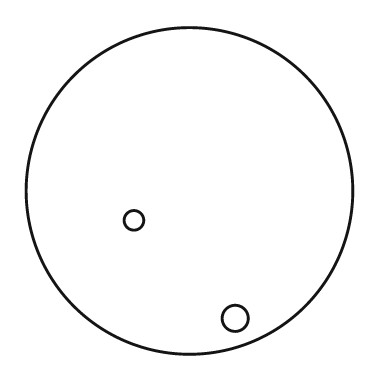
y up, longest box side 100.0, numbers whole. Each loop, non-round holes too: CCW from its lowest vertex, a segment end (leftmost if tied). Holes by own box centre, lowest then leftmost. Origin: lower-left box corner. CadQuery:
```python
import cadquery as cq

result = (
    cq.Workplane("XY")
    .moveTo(50.0, 50.0)
    .circle(50.0)
    .moveTo(64.0, 11.0)
    .circle(4.0)
    .moveTo(33.0, 41.0)
    .circle(3.0)
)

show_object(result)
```